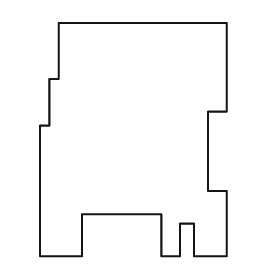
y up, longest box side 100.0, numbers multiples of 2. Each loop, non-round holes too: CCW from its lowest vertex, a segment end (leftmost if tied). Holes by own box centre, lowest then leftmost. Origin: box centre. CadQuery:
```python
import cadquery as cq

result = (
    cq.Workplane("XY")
    .moveTo(-40.0, -50.0)
    .lineTo(-22.0, -50.0)
    .lineTo(-22.0, -32.0)
    .lineTo(12.0, -32.0)
    .lineTo(12.0, -50.0)
    .lineTo(20.0, -50.0)
    .lineTo(20.0, -36.0)
    .lineTo(26.0, -36.0)
    .lineTo(26.0, -50.0)
    .lineTo(40.0, -50.0)
    .lineTo(40.0, -22.0)
    .lineTo(32.0, -22.0)
    .lineTo(32.0, 12.0)
    .lineTo(40.0, 12.0)
    .lineTo(40.0, 50.0)
    .lineTo(-32.0, 50.0)
    .lineTo(-32.0, 26.0)
    .lineTo(-36.0, 26.0)
    .lineTo(-36.0, 6.0)
    .lineTo(-40.0, 6.0)
    .close()
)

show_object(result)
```